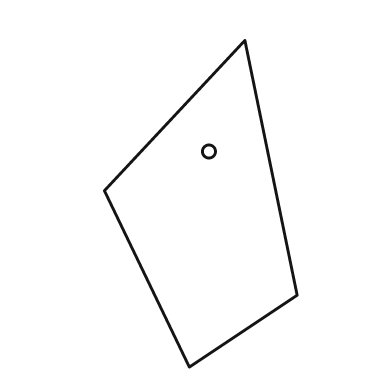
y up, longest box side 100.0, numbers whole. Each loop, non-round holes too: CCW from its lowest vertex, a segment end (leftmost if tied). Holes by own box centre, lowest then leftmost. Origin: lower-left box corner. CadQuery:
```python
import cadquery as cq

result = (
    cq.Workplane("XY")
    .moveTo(26.0, 0.0)
    .lineTo(59.0, 22.0)
    .lineTo(43.0, 100.0)
    .lineTo(0.0, 54.0)
    .close()
    .moveTo(32.0, 66.0)
    .circle(2.0)
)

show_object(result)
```